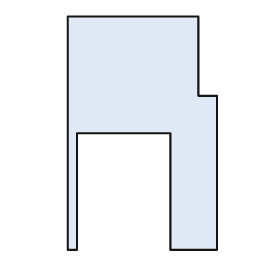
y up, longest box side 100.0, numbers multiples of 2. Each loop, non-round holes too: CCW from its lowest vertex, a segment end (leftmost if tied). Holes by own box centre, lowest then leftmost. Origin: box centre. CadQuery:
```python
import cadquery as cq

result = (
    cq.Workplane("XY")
    .moveTo(-32.0, -50.0)
    .lineTo(-28.0, -50.0)
    .lineTo(-28.0, 0.0)
    .lineTo(12.0, 0.0)
    .lineTo(12.0, -50.0)
    .lineTo(32.0, -50.0)
    .lineTo(32.0, 16.0)
    .lineTo(24.0, 16.0)
    .lineTo(24.0, 50.0)
    .lineTo(-32.0, 50.0)
    .close()
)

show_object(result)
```